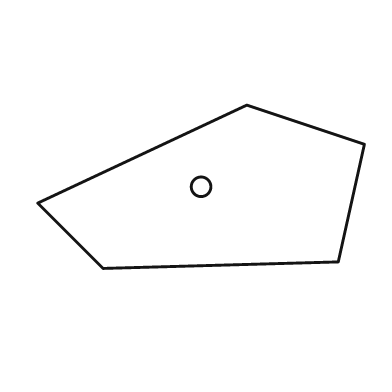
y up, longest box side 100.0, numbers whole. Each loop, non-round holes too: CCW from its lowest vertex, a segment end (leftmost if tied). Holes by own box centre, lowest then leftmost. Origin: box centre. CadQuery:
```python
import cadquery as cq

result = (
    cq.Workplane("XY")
    .moveTo(-30.0, -25.0)
    .lineTo(42.0, -23.0)
    .lineTo(50.0, 13.0)
    .lineTo(14.0, 25.0)
    .lineTo(-50.0, -5.0)
    .close()
    .moveTo(0.0, 0.0)
    .circle(3.0)
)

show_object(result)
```